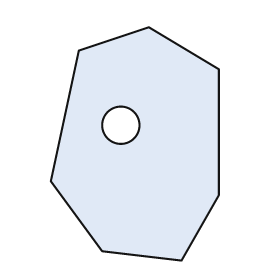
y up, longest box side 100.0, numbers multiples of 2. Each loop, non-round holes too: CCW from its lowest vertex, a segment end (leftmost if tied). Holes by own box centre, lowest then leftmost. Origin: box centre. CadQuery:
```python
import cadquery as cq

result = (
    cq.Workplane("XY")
    .moveTo(20.0, -50.0)
    .lineTo(36.0, -22.0)
    .lineTo(36.0, 32.0)
    .lineTo(6.0, 50.0)
    .lineTo(-24.0, 40.0)
    .lineTo(-36.0, -16.0)
    .lineTo(-14.0, -46.0)
    .close()
    .moveTo(-6.0, 8.0)
    .circle(8.0)
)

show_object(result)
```